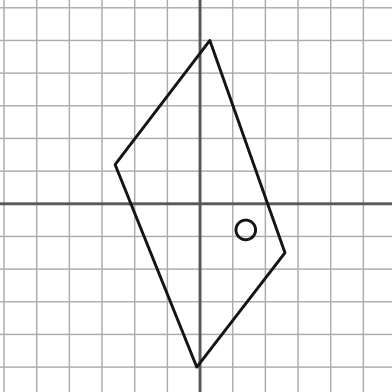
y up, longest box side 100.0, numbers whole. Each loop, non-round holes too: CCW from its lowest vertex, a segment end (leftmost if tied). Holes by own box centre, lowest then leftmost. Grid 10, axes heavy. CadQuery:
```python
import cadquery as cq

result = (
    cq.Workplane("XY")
    .moveTo(-1.0, -50.0)
    .lineTo(26.0, -15.0)
    .lineTo(3.0, 50.0)
    .lineTo(-26.0, 12.0)
    .close()
    .moveTo(14.0, -8.0)
    .circle(3.0)
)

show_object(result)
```